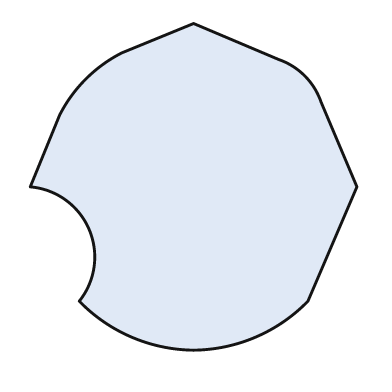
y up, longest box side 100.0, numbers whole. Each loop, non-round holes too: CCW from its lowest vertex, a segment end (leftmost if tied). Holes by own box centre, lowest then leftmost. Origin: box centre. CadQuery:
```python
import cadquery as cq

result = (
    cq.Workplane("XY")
    .moveTo(0.0, -50.0)
    .threePointArc((19.0, -46.0), (35.0, -35.0))
    .lineTo(50.0, 0.0)
    .lineTo(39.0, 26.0)
    .threePointArc((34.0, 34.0), (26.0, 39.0))
    .lineTo(0.0, 50.0)
    .lineTo(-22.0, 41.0)
    .threePointArc((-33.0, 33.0), (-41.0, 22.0))
    .lineTo(-50.0, 0.0)
    .threePointArc((-32.0, -13.0), (-35.0, -35.0))
    .threePointArc((-19.0, -46.0), (0.0, -50.0))
    .close()
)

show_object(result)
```